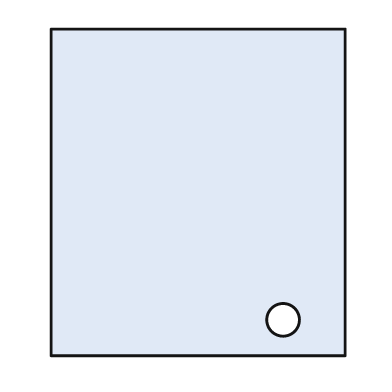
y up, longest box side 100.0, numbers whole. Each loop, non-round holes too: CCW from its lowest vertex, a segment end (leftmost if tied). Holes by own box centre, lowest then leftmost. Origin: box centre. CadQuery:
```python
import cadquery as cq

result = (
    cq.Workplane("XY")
    .moveTo(-45.0, -50.0)
    .lineTo(45.0, -50.0)
    .lineTo(45.0, 50.0)
    .lineTo(-45.0, 50.0)
    .close()
    .moveTo(26.0, -39.0)
    .circle(5.0)
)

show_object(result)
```